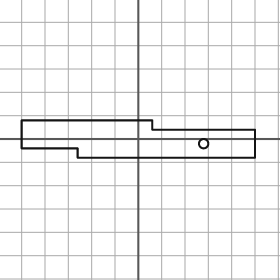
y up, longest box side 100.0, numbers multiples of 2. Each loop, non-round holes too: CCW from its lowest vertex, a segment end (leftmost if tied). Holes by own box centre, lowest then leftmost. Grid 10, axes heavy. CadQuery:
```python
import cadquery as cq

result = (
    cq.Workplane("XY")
    .moveTo(-26.0, -8.0)
    .lineTo(50.0, -8.0)
    .lineTo(50.0, 4.0)
    .lineTo(6.0, 4.0)
    .lineTo(6.0, 8.0)
    .lineTo(-50.0, 8.0)
    .lineTo(-50.0, -4.0)
    .lineTo(-26.0, -4.0)
    .close()
    .moveTo(28.0, -2.0)
    .circle(2.0)
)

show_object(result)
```